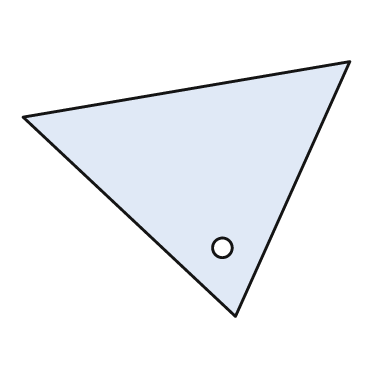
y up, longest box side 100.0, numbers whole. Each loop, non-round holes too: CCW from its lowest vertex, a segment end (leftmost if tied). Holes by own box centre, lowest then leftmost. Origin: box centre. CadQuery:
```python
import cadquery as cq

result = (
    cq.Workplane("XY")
    .moveTo(15.0, -39.0)
    .lineTo(50.0, 39.0)
    .lineTo(-50.0, 22.0)
    .close()
    .moveTo(11.0, -18.0)
    .circle(3.0)
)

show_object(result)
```